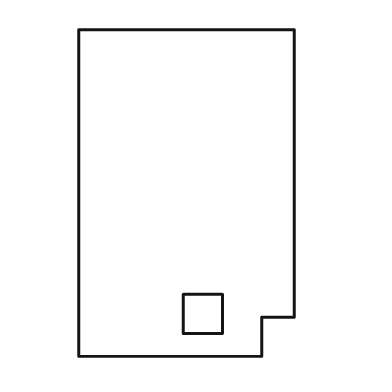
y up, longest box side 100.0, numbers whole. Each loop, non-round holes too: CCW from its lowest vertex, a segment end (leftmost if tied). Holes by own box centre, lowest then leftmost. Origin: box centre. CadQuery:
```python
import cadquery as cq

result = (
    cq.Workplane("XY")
    .moveTo(-33.0, -50.0)
    .lineTo(23.0, -50.0)
    .lineTo(23.0, -38.0)
    .lineTo(33.0, -38.0)
    .lineTo(33.0, 50.0)
    .lineTo(-33.0, 50.0)
    .close()
    .moveTo(-1.0, -43.0)
    .lineTo(11.0, -43.0)
    .lineTo(11.0, -31.0)
    .lineTo(-1.0, -31.0)
    .close()
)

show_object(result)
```